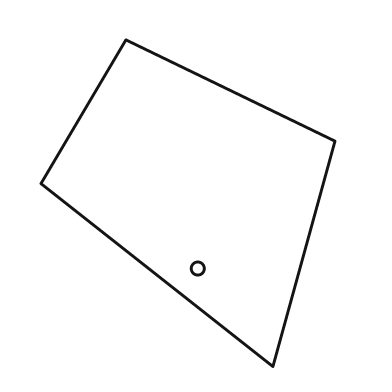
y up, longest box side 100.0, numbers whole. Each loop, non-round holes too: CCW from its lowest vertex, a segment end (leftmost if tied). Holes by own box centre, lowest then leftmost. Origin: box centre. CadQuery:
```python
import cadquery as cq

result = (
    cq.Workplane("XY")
    .moveTo(26.0, -50.0)
    .lineTo(45.0, 19.0)
    .lineTo(-19.0, 50.0)
    .lineTo(-45.0, 6.0)
    .close()
    .moveTo(3.0, -20.0)
    .circle(2.0)
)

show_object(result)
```